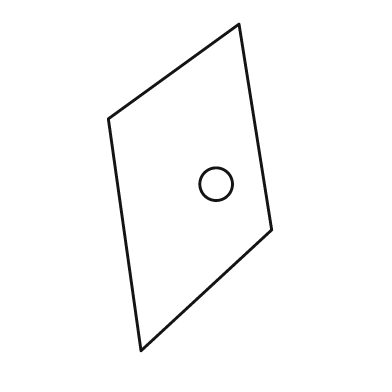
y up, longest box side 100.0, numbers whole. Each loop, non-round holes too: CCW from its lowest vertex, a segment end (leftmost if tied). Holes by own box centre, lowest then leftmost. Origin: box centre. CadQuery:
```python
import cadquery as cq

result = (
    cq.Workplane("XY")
    .moveTo(-15.0, -50.0)
    .lineTo(25.0, -13.0)
    .lineTo(15.0, 50.0)
    .lineTo(-25.0, 21.0)
    .close()
    .moveTo(8.0, 1.0)
    .circle(5.0)
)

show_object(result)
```